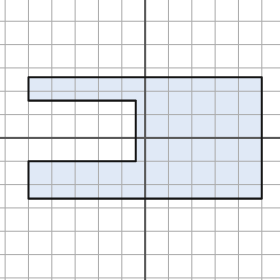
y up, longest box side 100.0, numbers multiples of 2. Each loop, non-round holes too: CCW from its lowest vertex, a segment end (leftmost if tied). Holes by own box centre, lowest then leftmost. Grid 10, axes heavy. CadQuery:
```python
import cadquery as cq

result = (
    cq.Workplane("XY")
    .moveTo(-50.0, -26.0)
    .lineTo(50.0, -26.0)
    .lineTo(50.0, 26.0)
    .lineTo(-50.0, 26.0)
    .lineTo(-50.0, 16.0)
    .lineTo(-4.0, 16.0)
    .lineTo(-4.0, -10.0)
    .lineTo(-50.0, -10.0)
    .close()
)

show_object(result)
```